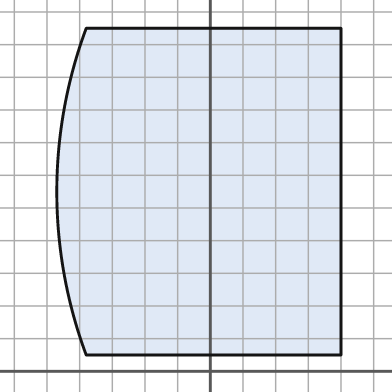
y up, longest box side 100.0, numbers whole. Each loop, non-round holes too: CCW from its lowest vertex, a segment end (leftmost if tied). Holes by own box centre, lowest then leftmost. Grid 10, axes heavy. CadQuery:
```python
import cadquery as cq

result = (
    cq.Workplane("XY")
    .moveTo(-38.0, 5.0)
    .lineTo(40.0, 5.0)
    .lineTo(40.0, 105.0)
    .lineTo(-38.0, 105.0)
    .threePointArc((-47.0, 55.0), (-38.0, 5.0))
    .close()
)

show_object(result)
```